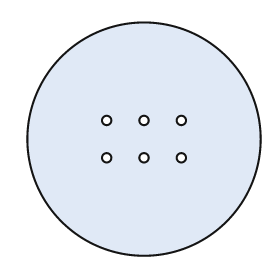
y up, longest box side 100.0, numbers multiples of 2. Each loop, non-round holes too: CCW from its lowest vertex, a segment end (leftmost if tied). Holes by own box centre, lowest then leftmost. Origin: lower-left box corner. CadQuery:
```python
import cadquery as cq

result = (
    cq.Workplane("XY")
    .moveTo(50.0, 50.0)
    .circle(50.0)
    .moveTo(34.0, 42.0)
    .circle(2.0)
    .moveTo(50.0, 42.0)
    .circle(2.0)
    .moveTo(66.0, 42.0)
    .circle(2.0)
    .moveTo(34.0, 58.0)
    .circle(2.0)
    .moveTo(50.0, 58.0)
    .circle(2.0)
    .moveTo(66.0, 58.0)
    .circle(2.0)
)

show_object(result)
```